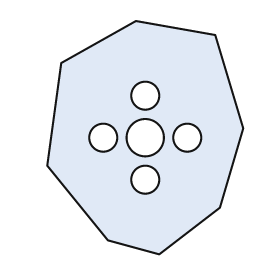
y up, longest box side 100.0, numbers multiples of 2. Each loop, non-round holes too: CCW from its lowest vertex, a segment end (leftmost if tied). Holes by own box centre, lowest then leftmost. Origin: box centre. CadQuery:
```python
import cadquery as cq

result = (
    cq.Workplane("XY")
    .moveTo(6.0, -50.0)
    .lineTo(32.0, -30.0)
    .lineTo(42.0, 4.0)
    .lineTo(30.0, 44.0)
    .lineTo(-4.0, 50.0)
    .lineTo(-36.0, 32.0)
    .lineTo(-42.0, -12.0)
    .lineTo(-16.0, -44.0)
    .close()
    .moveTo(0.0, -18.0)
    .circle(6.0)
    .moveTo(-18.0, 0.0)
    .circle(6.0)
    .moveTo(0.0, 0.0)
    .circle(8.0)
    .moveTo(18.0, 0.0)
    .circle(6.0)
    .moveTo(0.0, 18.0)
    .circle(6.0)
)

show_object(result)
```